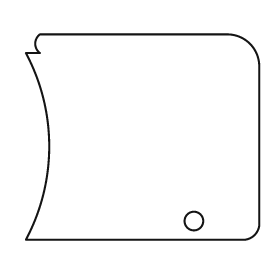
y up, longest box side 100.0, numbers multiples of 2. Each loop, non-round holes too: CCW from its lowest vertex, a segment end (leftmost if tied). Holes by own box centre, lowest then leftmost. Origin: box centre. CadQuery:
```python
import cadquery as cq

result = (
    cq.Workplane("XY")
    .moveTo(-50.0, -44.0)
    .lineTo(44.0, -44.0)
    .threePointArc((48.0, -42.0), (50.0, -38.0))
    .lineTo(50.0, 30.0)
    .threePointArc((46.0, 40.0), (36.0, 44.0))
    .lineTo(-44.0, 44.0)
    .threePointArc((-46.0, 40.0), (-44.0, 36.0))
    .lineTo(-50.0, 36.0)
    .threePointArc((-40.0, -4.0), (-50.0, -44.0))
    .close()
    .moveTo(22.0, -36.0)
    .circle(4.0)
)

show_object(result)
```